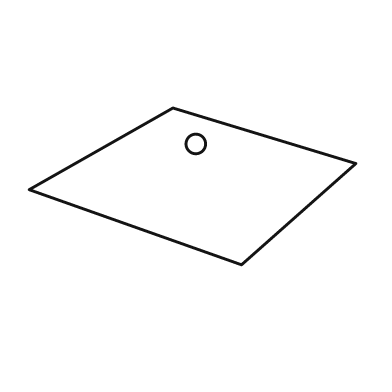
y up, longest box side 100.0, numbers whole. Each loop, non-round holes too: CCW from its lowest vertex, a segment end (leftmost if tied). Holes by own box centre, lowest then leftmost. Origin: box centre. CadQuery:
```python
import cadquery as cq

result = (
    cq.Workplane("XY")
    .moveTo(15.0, -24.0)
    .lineTo(50.0, 7.0)
    .lineTo(-6.0, 24.0)
    .lineTo(-50.0, -1.0)
    .close()
    .moveTo(1.0, 13.0)
    .circle(3.0)
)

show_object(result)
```